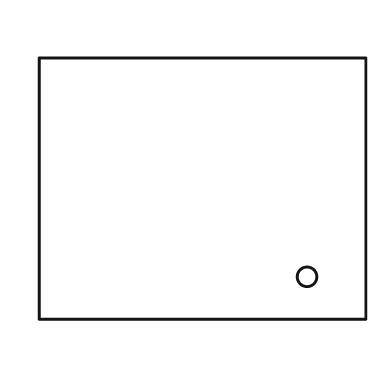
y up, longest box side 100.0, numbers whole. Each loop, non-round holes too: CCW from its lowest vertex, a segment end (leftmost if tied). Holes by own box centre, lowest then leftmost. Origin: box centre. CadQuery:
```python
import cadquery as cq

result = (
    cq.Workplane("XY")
    .moveTo(-50.0, -40.0)
    .lineTo(50.0, -40.0)
    .lineTo(50.0, 40.0)
    .lineTo(-50.0, 40.0)
    .close()
    .moveTo(32.0, -27.0)
    .circle(3.0)
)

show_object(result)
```